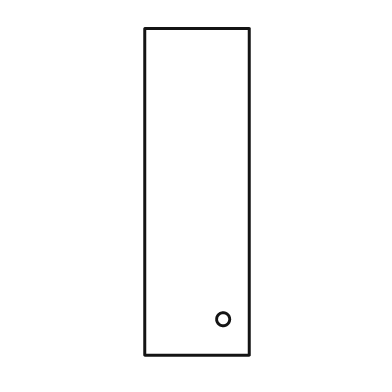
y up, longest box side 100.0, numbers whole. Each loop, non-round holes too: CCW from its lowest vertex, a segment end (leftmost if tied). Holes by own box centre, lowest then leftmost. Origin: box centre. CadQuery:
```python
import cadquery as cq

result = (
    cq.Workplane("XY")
    .moveTo(-16.0, -50.0)
    .lineTo(16.0, -50.0)
    .lineTo(16.0, 50.0)
    .lineTo(-16.0, 50.0)
    .close()
    .moveTo(8.0, -39.0)
    .circle(2.0)
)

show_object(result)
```